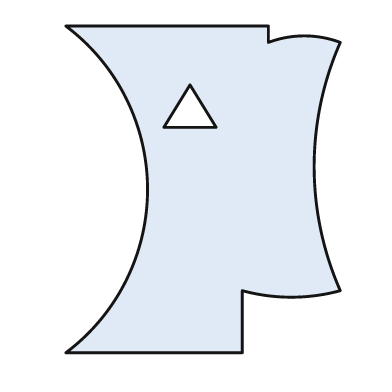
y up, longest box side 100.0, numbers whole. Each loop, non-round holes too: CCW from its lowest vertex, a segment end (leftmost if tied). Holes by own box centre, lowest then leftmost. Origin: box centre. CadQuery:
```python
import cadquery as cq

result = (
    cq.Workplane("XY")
    .moveTo(-42.0, -50.0)
    .lineTo(12.0, -50.0)
    .lineTo(12.0, -31.0)
    .threePointArc((27.0, -33.0), (42.0, -31.0))
    .threePointArc((34.0, 7.0), (42.0, 45.0))
    .threePointArc((31.0, 47.0), (20.0, 45.0))
    .lineTo(20.0, 50.0)
    .lineTo(-42.0, 50.0)
    .threePointArc((-17.0, 0.0), (-42.0, -50.0))
    .close()
    .moveTo(-12.0, 19.0)
    .lineTo(4.0, 19.0)
    .lineTo(-4.0, 32.0)
    .close()
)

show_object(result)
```